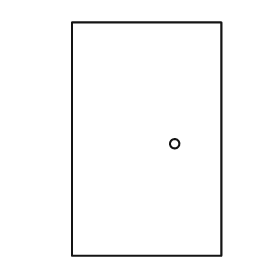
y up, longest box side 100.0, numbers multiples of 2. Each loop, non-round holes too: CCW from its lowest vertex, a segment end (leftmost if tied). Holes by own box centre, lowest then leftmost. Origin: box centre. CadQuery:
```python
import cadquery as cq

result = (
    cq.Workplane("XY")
    .moveTo(-32.0, -50.0)
    .lineTo(32.0, -50.0)
    .lineTo(32.0, 50.0)
    .lineTo(-32.0, 50.0)
    .close()
    .moveTo(12.0, -2.0)
    .circle(2.0)
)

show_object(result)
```